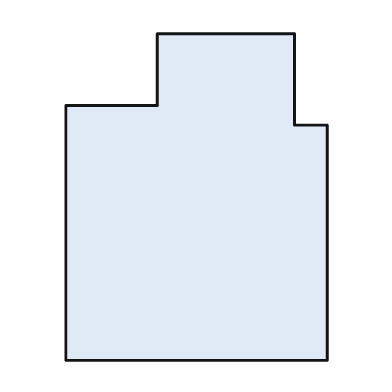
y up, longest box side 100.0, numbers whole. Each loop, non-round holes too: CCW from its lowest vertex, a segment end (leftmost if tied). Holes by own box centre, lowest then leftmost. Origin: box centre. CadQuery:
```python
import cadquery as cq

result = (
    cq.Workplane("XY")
    .moveTo(-40.0, -50.0)
    .lineTo(40.0, -50.0)
    .lineTo(40.0, 22.0)
    .lineTo(30.0, 22.0)
    .lineTo(30.0, 50.0)
    .lineTo(-12.0, 50.0)
    .lineTo(-12.0, 28.0)
    .lineTo(-40.0, 28.0)
    .close()
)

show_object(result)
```